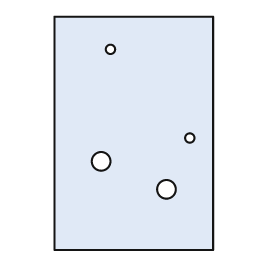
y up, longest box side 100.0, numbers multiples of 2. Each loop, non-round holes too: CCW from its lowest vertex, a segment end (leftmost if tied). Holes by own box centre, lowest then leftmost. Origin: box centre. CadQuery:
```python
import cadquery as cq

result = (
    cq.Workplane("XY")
    .moveTo(-34.0, -50.0)
    .lineTo(34.0, -50.0)
    .lineTo(34.0, 50.0)
    .lineTo(-34.0, 50.0)
    .close()
    .moveTo(14.0, -24.0)
    .circle(4.0)
    .moveTo(-14.0, -12.0)
    .circle(4.0)
    .moveTo(24.0, -2.0)
    .circle(2.0)
    .moveTo(-10.0, 36.0)
    .circle(2.0)
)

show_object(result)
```